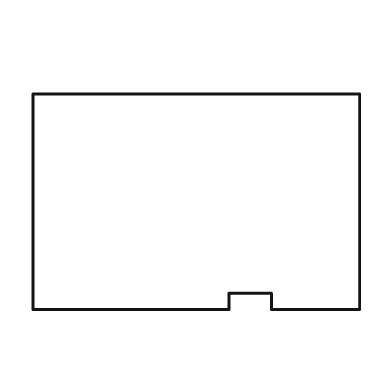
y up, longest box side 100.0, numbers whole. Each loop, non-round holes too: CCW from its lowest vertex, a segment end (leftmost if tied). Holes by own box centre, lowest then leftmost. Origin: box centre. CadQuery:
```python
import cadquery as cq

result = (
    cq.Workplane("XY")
    .moveTo(-50.0, -33.0)
    .lineTo(10.0, -33.0)
    .lineTo(10.0, -28.0)
    .lineTo(23.0, -28.0)
    .lineTo(23.0, -33.0)
    .lineTo(50.0, -33.0)
    .lineTo(50.0, 33.0)
    .lineTo(-50.0, 33.0)
    .close()
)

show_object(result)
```